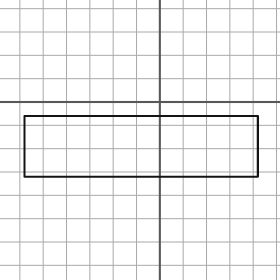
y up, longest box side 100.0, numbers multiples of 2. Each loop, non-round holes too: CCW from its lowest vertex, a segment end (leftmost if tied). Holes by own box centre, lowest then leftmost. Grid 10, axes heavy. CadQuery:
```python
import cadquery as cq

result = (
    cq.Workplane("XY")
    .moveTo(-58.0, -32.0)
    .lineTo(42.0, -32.0)
    .lineTo(42.0, -6.0)
    .lineTo(-58.0, -6.0)
    .close()
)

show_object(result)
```